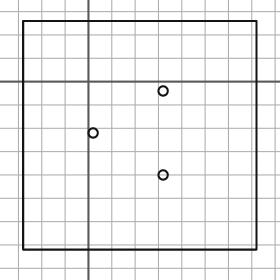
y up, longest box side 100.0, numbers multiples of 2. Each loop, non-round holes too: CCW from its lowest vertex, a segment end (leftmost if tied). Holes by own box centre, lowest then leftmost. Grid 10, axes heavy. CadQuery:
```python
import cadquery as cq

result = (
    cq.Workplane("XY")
    .moveTo(-28.0, -72.0)
    .lineTo(72.0, -72.0)
    .lineTo(72.0, 26.0)
    .lineTo(-28.0, 26.0)
    .close()
    .moveTo(32.0, -40.0)
    .circle(2.0)
    .moveTo(2.0, -22.0)
    .circle(2.0)
    .moveTo(32.0, -4.0)
    .circle(2.0)
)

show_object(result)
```